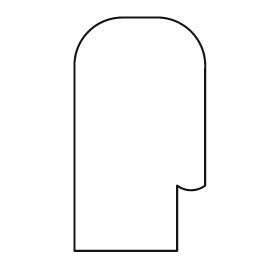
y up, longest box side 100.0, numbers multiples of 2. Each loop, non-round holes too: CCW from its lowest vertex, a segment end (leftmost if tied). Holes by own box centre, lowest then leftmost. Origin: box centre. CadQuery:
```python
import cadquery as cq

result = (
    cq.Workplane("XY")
    .moveTo(-28.0, -50.0)
    .lineTo(16.0, -50.0)
    .lineTo(16.0, -22.0)
    .threePointArc((22.0, -24.0), (28.0, -22.0))
    .lineTo(28.0, 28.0)
    .threePointArc((22.0, 44.0), (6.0, 50.0))
    .lineTo(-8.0, 50.0)
    .threePointArc((-22.0, 44.0), (-28.0, 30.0))
    .close()
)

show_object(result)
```